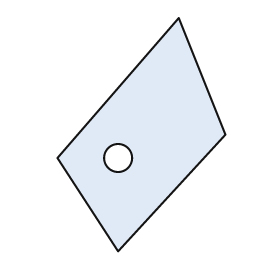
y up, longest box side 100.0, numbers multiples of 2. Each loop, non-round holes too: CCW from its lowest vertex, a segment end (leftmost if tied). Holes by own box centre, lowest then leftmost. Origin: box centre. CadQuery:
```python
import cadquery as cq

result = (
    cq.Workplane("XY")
    .moveTo(-10.0, -50.0)
    .lineTo(36.0, 0.0)
    .lineTo(16.0, 50.0)
    .lineTo(-36.0, -10.0)
    .close()
    .moveTo(-10.0, -10.0)
    .circle(6.0)
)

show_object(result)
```